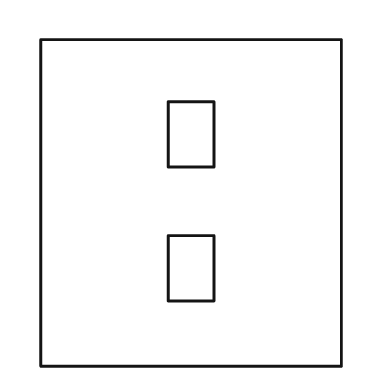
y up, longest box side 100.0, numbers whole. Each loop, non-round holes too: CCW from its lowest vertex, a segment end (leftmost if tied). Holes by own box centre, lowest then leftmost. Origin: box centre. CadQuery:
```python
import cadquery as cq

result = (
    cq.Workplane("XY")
    .moveTo(-46.0, -50.0)
    .lineTo(46.0, -50.0)
    .lineTo(46.0, 50.0)
    .lineTo(-46.0, 50.0)
    .close()
    .moveTo(-7.0, -30.0)
    .lineTo(7.0, -30.0)
    .lineTo(7.0, -10.0)
    .lineTo(-7.0, -10.0)
    .close()
    .moveTo(-7.0, 11.0)
    .lineTo(7.0, 11.0)
    .lineTo(7.0, 31.0)
    .lineTo(-7.0, 31.0)
    .close()
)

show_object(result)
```